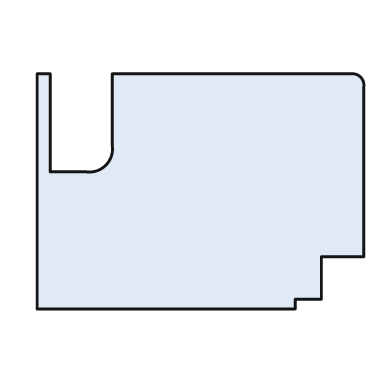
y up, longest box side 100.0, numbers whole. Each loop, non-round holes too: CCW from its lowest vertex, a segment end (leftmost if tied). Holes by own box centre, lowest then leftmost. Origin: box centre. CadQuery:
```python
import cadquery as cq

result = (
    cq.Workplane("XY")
    .moveTo(-50.0, -36.0)
    .lineTo(29.0, -36.0)
    .lineTo(29.0, -33.0)
    .lineTo(37.0, -33.0)
    .lineTo(37.0, -20.0)
    .lineTo(50.0, -20.0)
    .lineTo(50.0, 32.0)
    .threePointArc((49.0, 35.0), (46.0, 36.0))
    .lineTo(-27.0, 36.0)
    .lineTo(-27.0, 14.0)
    .threePointArc((-29.0, 8.0), (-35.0, 6.0))
    .lineTo(-46.0, 6.0)
    .lineTo(-46.0, 36.0)
    .lineTo(-50.0, 36.0)
    .close()
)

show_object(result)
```